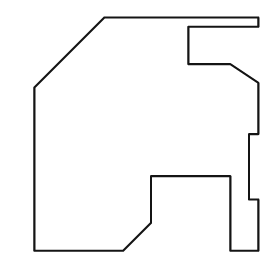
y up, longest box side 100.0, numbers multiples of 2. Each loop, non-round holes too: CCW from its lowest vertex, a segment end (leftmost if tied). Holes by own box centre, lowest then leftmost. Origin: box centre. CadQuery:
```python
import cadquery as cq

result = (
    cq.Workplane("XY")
    .moveTo(-48.0, -50.0)
    .lineTo(-10.0, -50.0)
    .lineTo(2.0, -38.0)
    .lineTo(2.0, -18.0)
    .lineTo(36.0, -18.0)
    .lineTo(36.0, -50.0)
    .lineTo(48.0, -50.0)
    .lineTo(48.0, -28.0)
    .lineTo(44.0, -28.0)
    .lineTo(44.0, 0.0)
    .lineTo(48.0, 0.0)
    .lineTo(48.0, 22.0)
    .lineTo(36.0, 30.0)
    .lineTo(18.0, 30.0)
    .lineTo(18.0, 46.0)
    .lineTo(48.0, 46.0)
    .lineTo(48.0, 50.0)
    .lineTo(-18.0, 50.0)
    .lineTo(-48.0, 20.0)
    .close()
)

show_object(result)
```